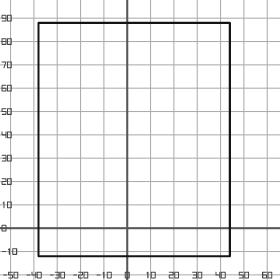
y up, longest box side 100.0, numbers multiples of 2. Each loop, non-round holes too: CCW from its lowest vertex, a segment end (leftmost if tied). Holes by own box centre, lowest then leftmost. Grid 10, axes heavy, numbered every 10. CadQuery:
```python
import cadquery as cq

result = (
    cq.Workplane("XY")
    .moveTo(-38.0, -12.0)
    .lineTo(44.0, -12.0)
    .lineTo(44.0, 88.0)
    .lineTo(-38.0, 88.0)
    .close()
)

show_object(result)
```